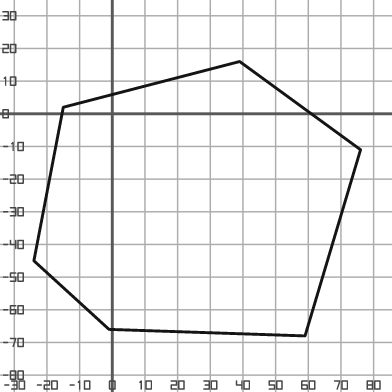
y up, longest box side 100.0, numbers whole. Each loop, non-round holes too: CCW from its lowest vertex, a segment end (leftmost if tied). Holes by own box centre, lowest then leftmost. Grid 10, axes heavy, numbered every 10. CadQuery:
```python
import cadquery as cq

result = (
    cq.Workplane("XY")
    .moveTo(59.0, -68.0)
    .lineTo(76.0, -11.0)
    .lineTo(39.0, 16.0)
    .lineTo(-15.0, 2.0)
    .lineTo(-24.0, -45.0)
    .lineTo(-1.0, -66.0)
    .close()
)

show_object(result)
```